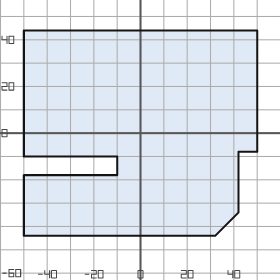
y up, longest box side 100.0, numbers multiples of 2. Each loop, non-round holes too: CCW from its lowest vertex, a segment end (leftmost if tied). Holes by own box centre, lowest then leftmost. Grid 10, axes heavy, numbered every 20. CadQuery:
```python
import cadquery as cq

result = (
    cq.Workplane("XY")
    .moveTo(-50.0, -44.0)
    .lineTo(32.0, -44.0)
    .lineTo(42.0, -34.0)
    .lineTo(42.0, -8.0)
    .lineTo(50.0, -8.0)
    .lineTo(50.0, 44.0)
    .lineTo(-50.0, 44.0)
    .lineTo(-50.0, -10.0)
    .lineTo(-10.0, -10.0)
    .lineTo(-10.0, -18.0)
    .lineTo(-50.0, -18.0)
    .close()
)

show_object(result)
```